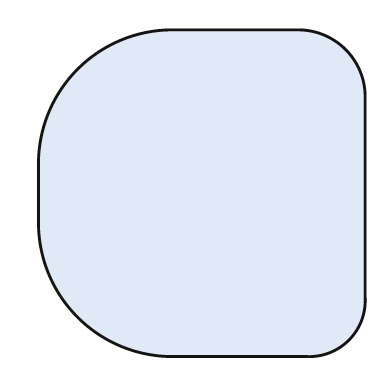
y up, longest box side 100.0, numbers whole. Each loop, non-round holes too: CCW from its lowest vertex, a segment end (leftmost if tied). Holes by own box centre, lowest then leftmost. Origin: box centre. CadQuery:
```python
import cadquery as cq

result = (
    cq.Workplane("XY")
    .moveTo(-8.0, -50.0)
    .lineTo(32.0, -50.0)
    .threePointArc((45.0, -45.0), (50.0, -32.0))
    .lineTo(50.0, 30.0)
    .threePointArc((44.0, 44.0), (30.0, 50.0))
    .lineTo(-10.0, 50.0)
    .threePointArc((-38.0, 38.0), (-50.0, 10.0))
    .lineTo(-50.0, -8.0)
    .threePointArc((-38.0, -38.0), (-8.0, -50.0))
    .close()
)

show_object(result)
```